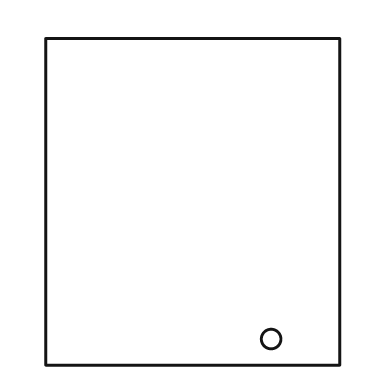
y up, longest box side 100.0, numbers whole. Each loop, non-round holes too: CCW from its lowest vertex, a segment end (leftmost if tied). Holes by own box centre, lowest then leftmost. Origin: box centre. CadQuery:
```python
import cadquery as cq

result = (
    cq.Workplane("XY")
    .moveTo(-45.0, -50.0)
    .lineTo(45.0, -50.0)
    .lineTo(45.0, 50.0)
    .lineTo(-45.0, 50.0)
    .close()
    .moveTo(24.0, -42.0)
    .circle(3.0)
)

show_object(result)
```